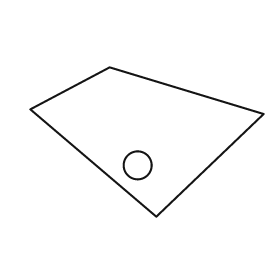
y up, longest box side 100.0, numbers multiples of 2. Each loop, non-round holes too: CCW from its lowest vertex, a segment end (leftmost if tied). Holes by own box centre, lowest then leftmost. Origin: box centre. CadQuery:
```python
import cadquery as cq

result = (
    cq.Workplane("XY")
    .moveTo(4.0, -32.0)
    .lineTo(50.0, 12.0)
    .lineTo(-16.0, 32.0)
    .lineTo(-50.0, 14.0)
    .close()
    .moveTo(-4.0, -10.0)
    .circle(6.0)
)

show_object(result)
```